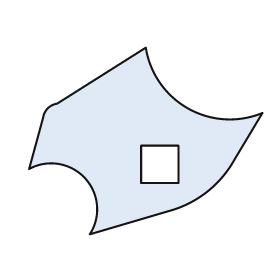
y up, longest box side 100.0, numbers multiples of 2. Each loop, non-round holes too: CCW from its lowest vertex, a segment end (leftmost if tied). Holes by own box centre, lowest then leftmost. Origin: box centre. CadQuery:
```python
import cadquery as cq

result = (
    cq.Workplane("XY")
    .moveTo(-24.0, -40.0)
    .lineTo(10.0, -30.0)
    .threePointArc((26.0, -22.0), (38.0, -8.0))
    .lineTo(50.0, 12.0)
    .threePointArc((18.0, 14.0), (0.0, 40.0))
    .lineTo(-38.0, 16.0)
    .threePointArc((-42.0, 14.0), (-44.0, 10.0))
    .lineTo(-50.0, -12.0)
    .threePointArc((-26.0, -16.0), (-24.0, -40.0))
    .close()
    .moveTo(-2.0, -18.0)
    .lineTo(14.0, -18.0)
    .lineTo(14.0, -2.0)
    .lineTo(-2.0, -2.0)
    .close()
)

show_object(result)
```